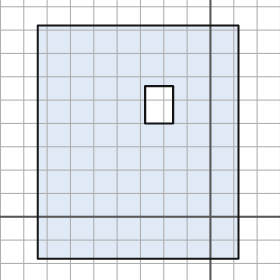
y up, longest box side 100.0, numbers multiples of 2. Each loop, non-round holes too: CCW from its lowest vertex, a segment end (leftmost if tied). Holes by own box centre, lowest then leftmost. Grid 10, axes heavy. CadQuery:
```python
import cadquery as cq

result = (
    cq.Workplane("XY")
    .moveTo(-74.0, -18.0)
    .lineTo(12.0, -18.0)
    .lineTo(12.0, 82.0)
    .lineTo(-74.0, 82.0)
    .close()
    .moveTo(-28.0, 40.0)
    .lineTo(-16.0, 40.0)
    .lineTo(-16.0, 56.0)
    .lineTo(-28.0, 56.0)
    .close()
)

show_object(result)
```